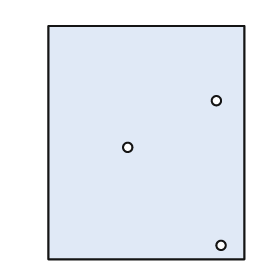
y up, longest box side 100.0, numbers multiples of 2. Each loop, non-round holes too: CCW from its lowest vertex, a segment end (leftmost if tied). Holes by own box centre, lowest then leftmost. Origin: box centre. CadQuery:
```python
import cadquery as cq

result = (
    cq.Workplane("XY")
    .moveTo(-42.0, -50.0)
    .lineTo(42.0, -50.0)
    .lineTo(42.0, 50.0)
    .lineTo(-42.0, 50.0)
    .close()
    .moveTo(32.0, -44.0)
    .circle(2.0)
    .moveTo(-8.0, -2.0)
    .circle(2.0)
    .moveTo(30.0, 18.0)
    .circle(2.0)
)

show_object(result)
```